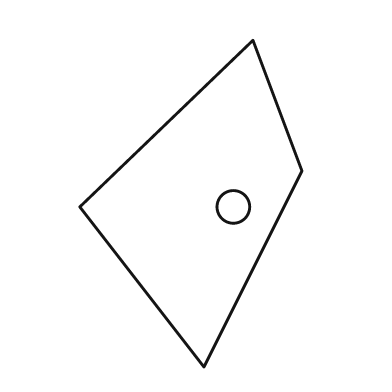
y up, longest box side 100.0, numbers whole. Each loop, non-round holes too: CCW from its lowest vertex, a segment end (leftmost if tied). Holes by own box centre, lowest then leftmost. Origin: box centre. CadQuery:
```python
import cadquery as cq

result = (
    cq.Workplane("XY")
    .moveTo(4.0, -50.0)
    .lineTo(34.0, 10.0)
    .lineTo(19.0, 50.0)
    .lineTo(-34.0, -1.0)
    .close()
    .moveTo(13.0, -1.0)
    .circle(5.0)
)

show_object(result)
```